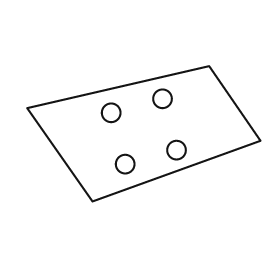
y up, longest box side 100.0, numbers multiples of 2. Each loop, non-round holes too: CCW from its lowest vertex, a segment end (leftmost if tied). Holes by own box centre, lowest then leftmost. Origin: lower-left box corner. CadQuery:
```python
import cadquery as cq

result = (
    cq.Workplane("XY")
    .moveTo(28.0, 0.0)
    .lineTo(100.0, 26.0)
    .lineTo(78.0, 58.0)
    .lineTo(0.0, 40.0)
    .close()
    .moveTo(42.0, 16.0)
    .circle(4.0)
    .moveTo(64.0, 22.0)
    .circle(4.0)
    .moveTo(36.0, 38.0)
    .circle(4.0)
    .moveTo(58.0, 44.0)
    .circle(4.0)
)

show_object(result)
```